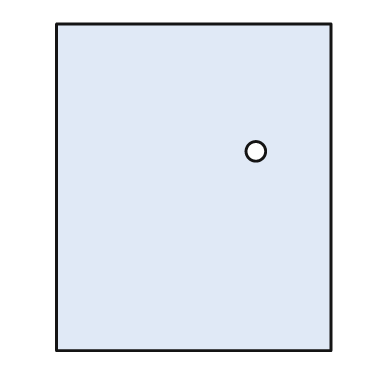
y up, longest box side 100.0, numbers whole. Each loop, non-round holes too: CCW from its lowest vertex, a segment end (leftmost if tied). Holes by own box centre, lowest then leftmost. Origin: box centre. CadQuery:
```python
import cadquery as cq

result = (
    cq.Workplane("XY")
    .moveTo(-42.0, -50.0)
    .lineTo(42.0, -50.0)
    .lineTo(42.0, 50.0)
    .lineTo(-42.0, 50.0)
    .close()
    .moveTo(19.0, 11.0)
    .circle(3.0)
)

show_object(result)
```